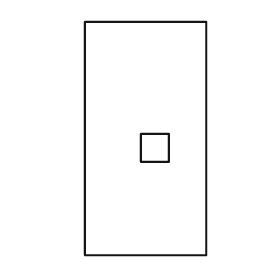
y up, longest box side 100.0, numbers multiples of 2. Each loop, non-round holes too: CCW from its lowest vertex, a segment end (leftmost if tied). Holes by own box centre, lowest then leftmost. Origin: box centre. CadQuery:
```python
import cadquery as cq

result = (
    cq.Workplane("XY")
    .moveTo(-26.0, -50.0)
    .lineTo(26.0, -50.0)
    .lineTo(26.0, 50.0)
    .lineTo(-26.0, 50.0)
    .close()
    .moveTo(-2.0, -10.0)
    .lineTo(10.0, -10.0)
    .lineTo(10.0, 2.0)
    .lineTo(-2.0, 2.0)
    .close()
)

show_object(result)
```